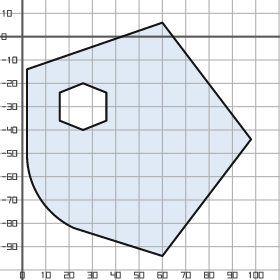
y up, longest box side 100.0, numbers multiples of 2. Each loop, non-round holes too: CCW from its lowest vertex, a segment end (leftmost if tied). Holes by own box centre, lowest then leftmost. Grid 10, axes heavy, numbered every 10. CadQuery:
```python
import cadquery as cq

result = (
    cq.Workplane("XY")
    .moveTo(60.0, -94.0)
    .lineTo(98.0, -44.0)
    .lineTo(60.0, 6.0)
    .lineTo(2.0, -14.0)
    .lineTo(2.0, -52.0)
    .threePointArc((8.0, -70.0), (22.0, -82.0))
    .close()
    .moveTo(26.0, -40.0)
    .lineTo(36.0, -36.0)
    .lineTo(36.0, -24.0)
    .lineTo(26.0, -20.0)
    .lineTo(16.0, -24.0)
    .lineTo(16.0, -36.0)
    .close()
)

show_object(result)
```